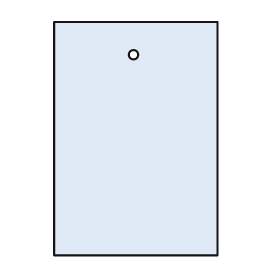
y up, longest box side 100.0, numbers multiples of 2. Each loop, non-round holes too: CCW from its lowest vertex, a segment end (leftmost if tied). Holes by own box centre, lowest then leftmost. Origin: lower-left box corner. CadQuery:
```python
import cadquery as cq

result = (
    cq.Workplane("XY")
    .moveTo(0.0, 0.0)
    .lineTo(70.0, 0.0)
    .lineTo(70.0, 100.0)
    .lineTo(0.0, 100.0)
    .close()
    .moveTo(34.0, 86.0)
    .circle(2.0)
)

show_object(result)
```